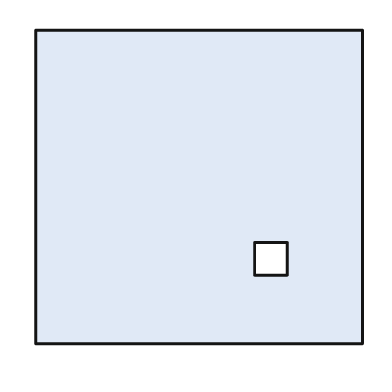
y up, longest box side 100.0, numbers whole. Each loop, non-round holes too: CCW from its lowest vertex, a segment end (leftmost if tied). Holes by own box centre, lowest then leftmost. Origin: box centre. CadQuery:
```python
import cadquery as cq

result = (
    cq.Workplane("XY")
    .moveTo(-50.0, -48.0)
    .lineTo(50.0, -48.0)
    .lineTo(50.0, 48.0)
    .lineTo(-50.0, 48.0)
    .close()
    .moveTo(17.0, -27.0)
    .lineTo(27.0, -27.0)
    .lineTo(27.0, -17.0)
    .lineTo(17.0, -17.0)
    .close()
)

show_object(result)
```